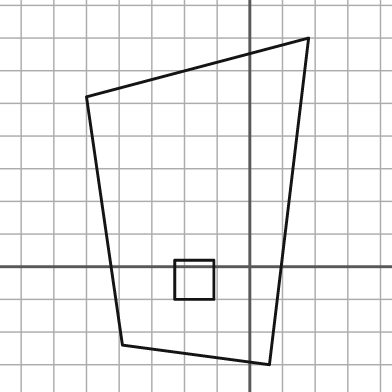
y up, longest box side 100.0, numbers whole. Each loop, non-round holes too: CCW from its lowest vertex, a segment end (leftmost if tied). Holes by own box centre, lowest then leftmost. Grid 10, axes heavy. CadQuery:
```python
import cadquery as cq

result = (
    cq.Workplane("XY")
    .moveTo(6.0, -30.0)
    .lineTo(18.0, 70.0)
    .lineTo(-50.0, 52.0)
    .lineTo(-39.0, -24.0)
    .close()
    .moveTo(-23.0, -10.0)
    .lineTo(-11.0, -10.0)
    .lineTo(-11.0, 2.0)
    .lineTo(-23.0, 2.0)
    .close()
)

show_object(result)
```